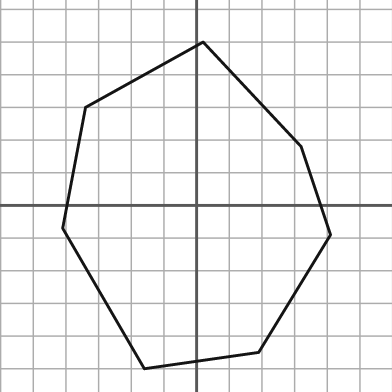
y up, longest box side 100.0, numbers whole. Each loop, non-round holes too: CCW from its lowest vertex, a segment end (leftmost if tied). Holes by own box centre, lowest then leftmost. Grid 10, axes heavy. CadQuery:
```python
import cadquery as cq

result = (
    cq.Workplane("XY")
    .moveTo(-16.0, -50.0)
    .lineTo(19.0, -45.0)
    .lineTo(41.0, -9.0)
    .lineTo(32.0, 18.0)
    .lineTo(2.0, 50.0)
    .lineTo(-34.0, 30.0)
    .lineTo(-41.0, -7.0)
    .close()
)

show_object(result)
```